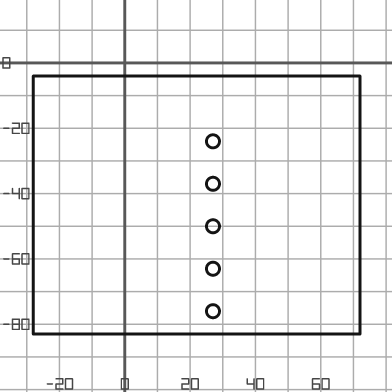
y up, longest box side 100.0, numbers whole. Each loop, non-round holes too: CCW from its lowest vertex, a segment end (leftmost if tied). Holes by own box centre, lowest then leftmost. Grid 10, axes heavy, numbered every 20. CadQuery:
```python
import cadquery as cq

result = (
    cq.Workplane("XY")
    .moveTo(-28.0, -83.0)
    .lineTo(72.0, -83.0)
    .lineTo(72.0, -4.0)
    .lineTo(-28.0, -4.0)
    .close()
    .moveTo(27.0, -76.0)
    .circle(2.0)
    .moveTo(27.0, -63.0)
    .circle(2.0)
    .moveTo(27.0, -50.0)
    .circle(2.0)
    .moveTo(27.0, -37.0)
    .circle(2.0)
    .moveTo(27.0, -24.0)
    .circle(2.0)
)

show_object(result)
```